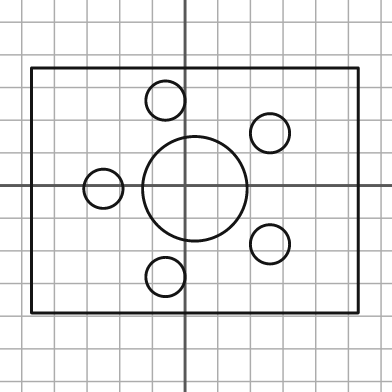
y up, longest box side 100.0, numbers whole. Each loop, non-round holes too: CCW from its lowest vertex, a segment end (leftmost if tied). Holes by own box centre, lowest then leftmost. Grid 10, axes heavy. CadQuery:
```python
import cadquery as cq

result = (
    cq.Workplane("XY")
    .moveTo(-47.0, -39.0)
    .lineTo(53.0, -39.0)
    .lineTo(53.0, 36.0)
    .lineTo(-47.0, 36.0)
    .close()
    .moveTo(-6.0, -28.0)
    .circle(6.0)
    .moveTo(26.0, -18.0)
    .circle(6.0)
    .moveTo(-25.0, -1.0)
    .circle(6.0)
    .moveTo(3.0, -1.0)
    .circle(16.0)
    .moveTo(26.0, 16.0)
    .circle(6.0)
    .moveTo(-6.0, 26.0)
    .circle(6.0)
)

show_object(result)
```